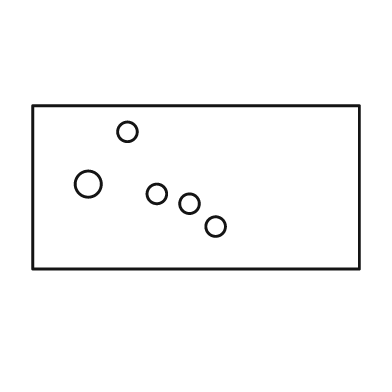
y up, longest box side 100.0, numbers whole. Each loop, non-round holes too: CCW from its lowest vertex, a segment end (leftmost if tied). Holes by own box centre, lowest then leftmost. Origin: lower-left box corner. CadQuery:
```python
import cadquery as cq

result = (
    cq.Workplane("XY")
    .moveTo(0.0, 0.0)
    .lineTo(100.0, 0.0)
    .lineTo(100.0, 50.0)
    .lineTo(0.0, 50.0)
    .close()
    .moveTo(56.0, 13.0)
    .circle(3.0)
    .moveTo(48.0, 20.0)
    .circle(3.0)
    .moveTo(38.0, 23.0)
    .circle(3.0)
    .moveTo(17.0, 26.0)
    .circle(4.0)
    .moveTo(29.0, 42.0)
    .circle(3.0)
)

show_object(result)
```